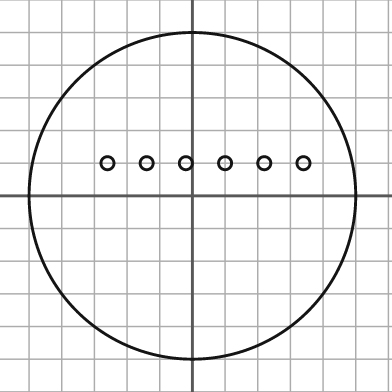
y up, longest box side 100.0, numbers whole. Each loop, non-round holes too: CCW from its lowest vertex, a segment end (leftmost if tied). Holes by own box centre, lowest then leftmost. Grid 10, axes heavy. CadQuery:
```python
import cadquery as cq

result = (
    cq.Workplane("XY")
    .moveTo(0.0, 0.0)
    .circle(50.0)
    .moveTo(-26.0, 10.0)
    .circle(2.0)
    .moveTo(-14.0, 10.0)
    .circle(2.0)
    .moveTo(-2.0, 10.0)
    .circle(2.0)
    .moveTo(10.0, 10.0)
    .circle(2.0)
    .moveTo(22.0, 10.0)
    .circle(2.0)
    .moveTo(34.0, 10.0)
    .circle(2.0)
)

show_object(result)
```